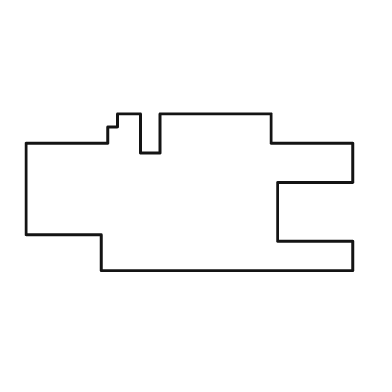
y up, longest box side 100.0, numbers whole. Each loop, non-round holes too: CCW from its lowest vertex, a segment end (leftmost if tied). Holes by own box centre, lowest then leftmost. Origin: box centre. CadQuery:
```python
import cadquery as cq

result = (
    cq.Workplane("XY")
    .moveTo(-27.0, -24.0)
    .lineTo(50.0, -24.0)
    .lineTo(50.0, -15.0)
    .lineTo(27.0, -15.0)
    .lineTo(27.0, 3.0)
    .lineTo(50.0, 3.0)
    .lineTo(50.0, 15.0)
    .lineTo(25.0, 15.0)
    .lineTo(25.0, 24.0)
    .lineTo(-9.0, 24.0)
    .lineTo(-9.0, 12.0)
    .lineTo(-15.0, 12.0)
    .lineTo(-15.0, 24.0)
    .lineTo(-22.0, 24.0)
    .lineTo(-22.0, 20.0)
    .lineTo(-25.0, 20.0)
    .lineTo(-25.0, 15.0)
    .lineTo(-50.0, 15.0)
    .lineTo(-50.0, -13.0)
    .lineTo(-27.0, -13.0)
    .close()
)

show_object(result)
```